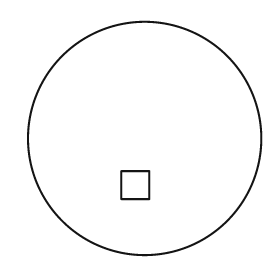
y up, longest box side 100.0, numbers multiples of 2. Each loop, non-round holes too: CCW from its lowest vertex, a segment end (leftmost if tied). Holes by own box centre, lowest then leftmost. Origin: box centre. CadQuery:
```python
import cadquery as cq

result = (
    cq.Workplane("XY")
    .moveTo(0.0, 0.0)
    .circle(50.0)
    .moveTo(-10.0, -26.0)
    .lineTo(2.0, -26.0)
    .lineTo(2.0, -14.0)
    .lineTo(-10.0, -14.0)
    .close()
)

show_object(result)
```